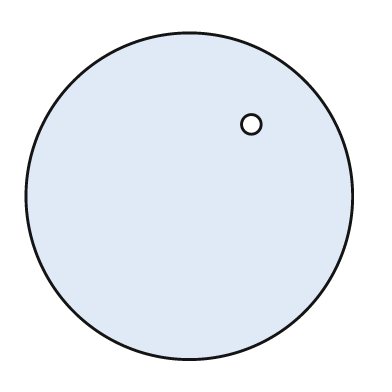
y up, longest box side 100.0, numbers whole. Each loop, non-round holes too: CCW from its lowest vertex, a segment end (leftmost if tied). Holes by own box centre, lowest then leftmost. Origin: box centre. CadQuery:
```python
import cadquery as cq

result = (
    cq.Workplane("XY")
    .moveTo(0.0, 0.0)
    .circle(50.0)
    .moveTo(19.0, 22.0)
    .circle(3.0)
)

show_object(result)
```